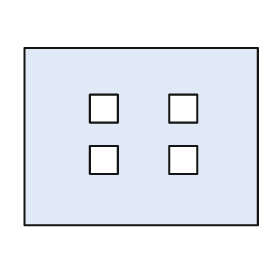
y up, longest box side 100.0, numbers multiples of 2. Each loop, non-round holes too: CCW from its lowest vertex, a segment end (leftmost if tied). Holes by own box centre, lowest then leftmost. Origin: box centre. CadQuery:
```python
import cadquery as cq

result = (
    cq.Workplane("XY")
    .moveTo(-50.0, -38.0)
    .lineTo(50.0, -38.0)
    .lineTo(50.0, 38.0)
    .lineTo(-50.0, 38.0)
    .close()
    .moveTo(-22.0, -16.0)
    .lineTo(-10.0, -16.0)
    .lineTo(-10.0, -4.0)
    .lineTo(-22.0, -4.0)
    .close()
    .moveTo(12.0, -16.0)
    .lineTo(24.0, -16.0)
    .lineTo(24.0, -4.0)
    .lineTo(12.0, -4.0)
    .close()
    .moveTo(-22.0, 6.0)
    .lineTo(-10.0, 6.0)
    .lineTo(-10.0, 18.0)
    .lineTo(-22.0, 18.0)
    .close()
    .moveTo(12.0, 6.0)
    .lineTo(24.0, 6.0)
    .lineTo(24.0, 18.0)
    .lineTo(12.0, 18.0)
    .close()
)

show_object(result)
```